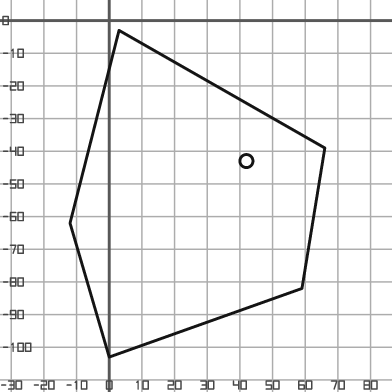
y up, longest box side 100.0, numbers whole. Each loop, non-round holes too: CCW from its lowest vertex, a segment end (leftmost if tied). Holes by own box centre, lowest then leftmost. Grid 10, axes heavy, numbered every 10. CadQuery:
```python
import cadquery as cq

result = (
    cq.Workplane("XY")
    .moveTo(0.0, -103.0)
    .lineTo(59.0, -82.0)
    .lineTo(66.0, -39.0)
    .lineTo(3.0, -3.0)
    .lineTo(-12.0, -62.0)
    .close()
    .moveTo(42.0, -43.0)
    .circle(2.0)
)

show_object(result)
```